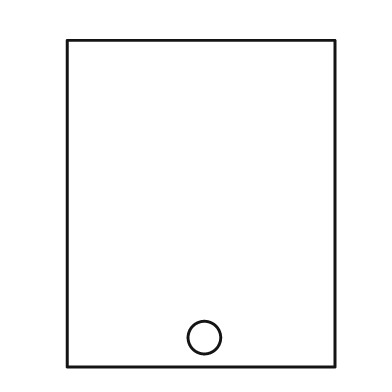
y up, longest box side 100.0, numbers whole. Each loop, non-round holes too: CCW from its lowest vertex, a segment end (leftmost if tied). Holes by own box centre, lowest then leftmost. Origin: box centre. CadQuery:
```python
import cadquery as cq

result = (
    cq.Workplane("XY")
    .moveTo(-41.0, -50.0)
    .lineTo(41.0, -50.0)
    .lineTo(41.0, 50.0)
    .lineTo(-41.0, 50.0)
    .close()
    .moveTo(1.0, -41.0)
    .circle(5.0)
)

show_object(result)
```